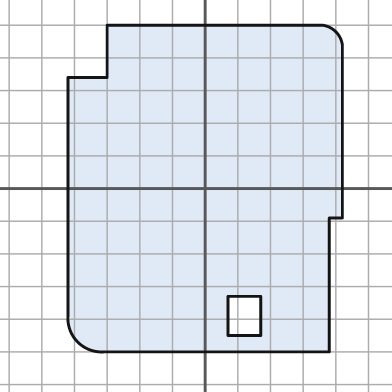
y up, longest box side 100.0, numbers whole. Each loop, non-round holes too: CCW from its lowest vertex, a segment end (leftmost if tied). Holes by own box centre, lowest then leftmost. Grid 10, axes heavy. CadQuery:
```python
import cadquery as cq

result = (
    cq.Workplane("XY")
    .moveTo(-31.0, -50.0)
    .lineTo(38.0, -50.0)
    .lineTo(38.0, -9.0)
    .lineTo(42.0, -9.0)
    .lineTo(42.0, 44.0)
    .threePointArc((40.0, 48.0), (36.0, 50.0))
    .lineTo(-30.0, 50.0)
    .lineTo(-30.0, 34.0)
    .lineTo(-42.0, 34.0)
    .lineTo(-42.0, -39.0)
    .threePointArc((-39.0, -47.0), (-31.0, -50.0))
    .close()
    .moveTo(7.0, -45.0)
    .lineTo(17.0, -45.0)
    .lineTo(17.0, -33.0)
    .lineTo(7.0, -33.0)
    .close()
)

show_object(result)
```